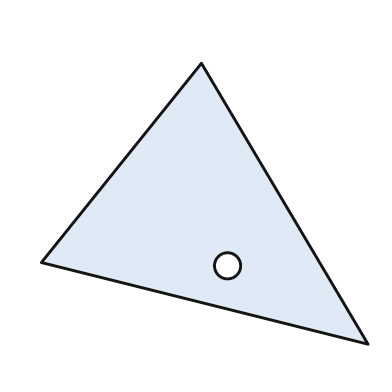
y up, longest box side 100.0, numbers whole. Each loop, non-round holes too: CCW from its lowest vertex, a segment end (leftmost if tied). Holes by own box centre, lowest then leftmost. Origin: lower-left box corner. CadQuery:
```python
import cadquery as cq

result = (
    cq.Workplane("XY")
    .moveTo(100.0, 0.0)
    .lineTo(49.0, 86.0)
    .lineTo(0.0, 25.0)
    .close()
    .moveTo(57.0, 24.0)
    .circle(4.0)
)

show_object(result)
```